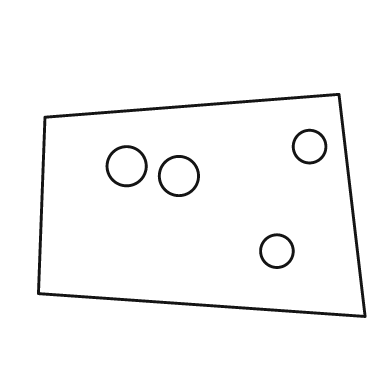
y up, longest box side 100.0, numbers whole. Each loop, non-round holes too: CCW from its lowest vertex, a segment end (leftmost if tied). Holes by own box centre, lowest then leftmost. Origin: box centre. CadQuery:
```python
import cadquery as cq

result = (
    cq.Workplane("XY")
    .moveTo(50.0, -34.0)
    .lineTo(42.0, 34.0)
    .lineTo(-48.0, 27.0)
    .lineTo(-50.0, -27.0)
    .close()
    .moveTo(23.0, -14.0)
    .circle(5.0)
    .moveTo(-7.0, 9.0)
    .circle(6.0)
    .moveTo(-23.0, 12.0)
    .circle(6.0)
    .moveTo(33.0, 18.0)
    .circle(5.0)
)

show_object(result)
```